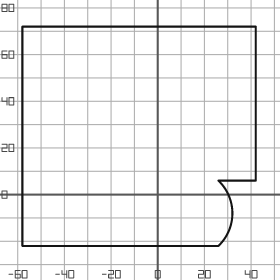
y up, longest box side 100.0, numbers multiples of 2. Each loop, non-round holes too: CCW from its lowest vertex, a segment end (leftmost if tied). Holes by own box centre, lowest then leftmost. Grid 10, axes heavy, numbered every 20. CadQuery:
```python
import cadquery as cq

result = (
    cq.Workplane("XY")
    .moveTo(-58.0, -22.0)
    .lineTo(26.0, -22.0)
    .threePointArc((32.0, -8.0), (26.0, 6.0))
    .lineTo(42.0, 6.0)
    .lineTo(42.0, 72.0)
    .lineTo(-58.0, 72.0)
    .close()
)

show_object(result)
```